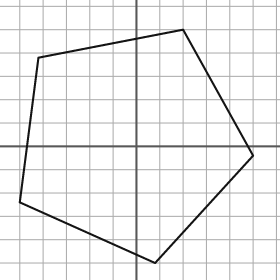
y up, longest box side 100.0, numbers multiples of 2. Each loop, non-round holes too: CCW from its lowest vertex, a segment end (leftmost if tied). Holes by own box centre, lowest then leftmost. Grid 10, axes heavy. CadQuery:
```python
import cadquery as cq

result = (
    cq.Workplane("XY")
    .moveTo(8.0, -50.0)
    .lineTo(50.0, -4.0)
    .lineTo(20.0, 50.0)
    .lineTo(-42.0, 38.0)
    .lineTo(-50.0, -24.0)
    .close()
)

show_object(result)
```